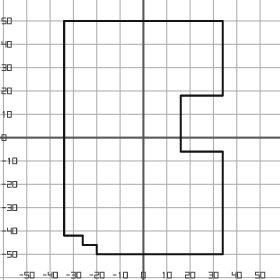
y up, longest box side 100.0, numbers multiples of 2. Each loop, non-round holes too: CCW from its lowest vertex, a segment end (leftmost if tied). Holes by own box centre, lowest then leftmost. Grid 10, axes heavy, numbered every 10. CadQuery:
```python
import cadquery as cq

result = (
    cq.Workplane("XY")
    .moveTo(-20.0, -50.0)
    .lineTo(34.0, -50.0)
    .lineTo(34.0, -6.0)
    .lineTo(16.0, -6.0)
    .lineTo(16.0, 18.0)
    .lineTo(34.0, 18.0)
    .lineTo(34.0, 50.0)
    .lineTo(-34.0, 50.0)
    .lineTo(-34.0, -42.0)
    .lineTo(-26.0, -42.0)
    .lineTo(-26.0, -46.0)
    .lineTo(-20.0, -46.0)
    .close()
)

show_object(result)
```